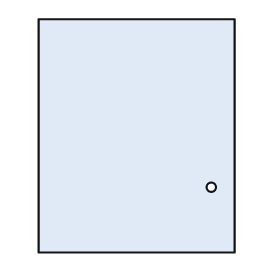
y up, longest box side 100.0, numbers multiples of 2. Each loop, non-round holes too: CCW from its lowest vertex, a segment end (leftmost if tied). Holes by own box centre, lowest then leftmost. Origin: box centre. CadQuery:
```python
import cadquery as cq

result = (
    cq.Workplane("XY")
    .moveTo(-42.0, -50.0)
    .lineTo(42.0, -50.0)
    .lineTo(42.0, 50.0)
    .lineTo(-42.0, 50.0)
    .close()
    .moveTo(32.0, -22.0)
    .circle(2.0)
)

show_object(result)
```